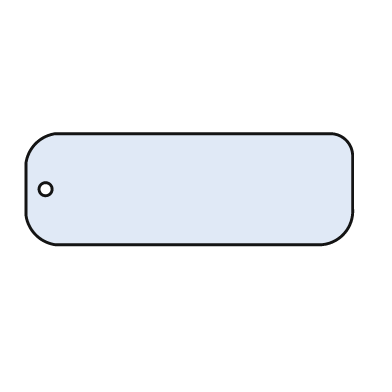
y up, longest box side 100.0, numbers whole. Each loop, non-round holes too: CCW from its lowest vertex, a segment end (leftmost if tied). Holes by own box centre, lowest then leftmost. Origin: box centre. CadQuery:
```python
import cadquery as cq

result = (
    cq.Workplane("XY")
    .moveTo(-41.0, -17.0)
    .lineTo(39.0, -17.0)
    .threePointArc((47.0, -14.0), (50.0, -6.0))
    .lineTo(50.0, 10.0)
    .threePointArc((48.0, 15.0), (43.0, 17.0))
    .lineTo(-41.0, 17.0)
    .threePointArc((-47.0, 14.0), (-50.0, 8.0))
    .lineTo(-50.0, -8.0)
    .threePointArc((-47.0, -14.0), (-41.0, -17.0))
    .close()
    .moveTo(-44.0, 0.0)
    .circle(2.0)
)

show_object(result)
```